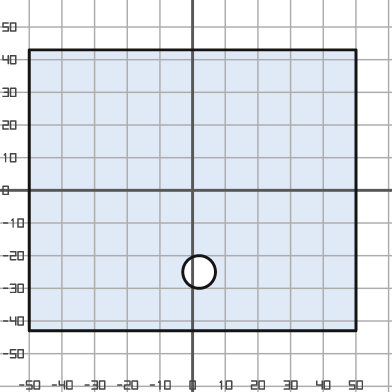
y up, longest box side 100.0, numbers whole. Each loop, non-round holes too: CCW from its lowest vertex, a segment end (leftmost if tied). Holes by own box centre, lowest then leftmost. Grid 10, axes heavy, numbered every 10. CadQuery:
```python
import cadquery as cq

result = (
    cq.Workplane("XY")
    .moveTo(-50.0, -43.0)
    .lineTo(50.0, -43.0)
    .lineTo(50.0, 43.0)
    .lineTo(-50.0, 43.0)
    .close()
    .moveTo(2.0, -25.0)
    .circle(5.0)
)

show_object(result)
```